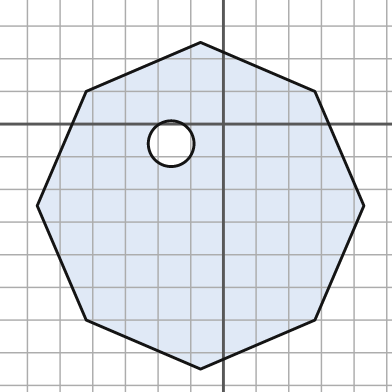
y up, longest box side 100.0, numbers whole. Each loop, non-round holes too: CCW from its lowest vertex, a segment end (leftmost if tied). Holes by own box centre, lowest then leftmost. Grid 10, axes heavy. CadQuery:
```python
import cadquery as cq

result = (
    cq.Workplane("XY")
    .moveTo(-7.0, -75.0)
    .lineTo(28.0, -60.0)
    .lineTo(43.0, -25.0)
    .lineTo(28.0, 10.0)
    .lineTo(-7.0, 25.0)
    .lineTo(-42.0, 10.0)
    .lineTo(-57.0, -25.0)
    .lineTo(-42.0, -60.0)
    .close()
    .moveTo(-16.0, -6.0)
    .circle(7.0)
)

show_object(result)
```